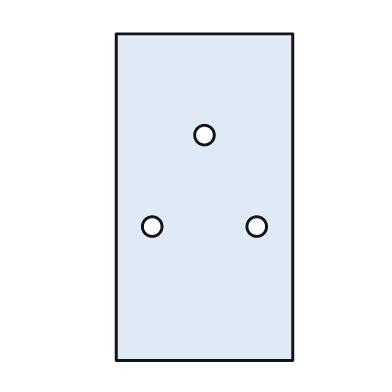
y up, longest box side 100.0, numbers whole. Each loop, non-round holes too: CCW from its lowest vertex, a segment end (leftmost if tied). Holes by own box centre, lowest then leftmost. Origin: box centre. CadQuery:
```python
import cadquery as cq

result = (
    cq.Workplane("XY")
    .moveTo(-27.0, -50.0)
    .lineTo(27.0, -50.0)
    .lineTo(27.0, 50.0)
    .lineTo(-27.0, 50.0)
    .close()
    .moveTo(-16.0, -9.0)
    .circle(3.0)
    .moveTo(16.0, -9.0)
    .circle(3.0)
    .moveTo(0.0, 19.0)
    .circle(3.0)
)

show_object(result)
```